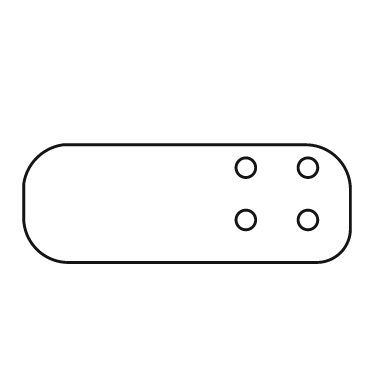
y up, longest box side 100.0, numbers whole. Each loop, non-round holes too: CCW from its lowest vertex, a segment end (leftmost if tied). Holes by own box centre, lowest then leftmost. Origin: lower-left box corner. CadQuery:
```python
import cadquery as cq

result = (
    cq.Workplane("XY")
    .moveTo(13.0, 0.0)
    .lineTo(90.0, 0.0)
    .threePointArc((97.0, 3.0), (100.0, 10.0))
    .lineTo(100.0, 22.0)
    .threePointArc((96.0, 32.0), (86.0, 36.0))
    .lineTo(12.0, 36.0)
    .threePointArc((4.0, 32.0), (0.0, 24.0))
    .lineTo(0.0, 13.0)
    .threePointArc((4.0, 4.0), (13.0, 0.0))
    .close()
    .moveTo(68.0, 13.0)
    .circle(3.0)
    .moveTo(87.0, 13.0)
    .circle(3.0)
    .moveTo(68.0, 29.0)
    .circle(3.0)
    .moveTo(87.0, 29.0)
    .circle(3.0)
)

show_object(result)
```